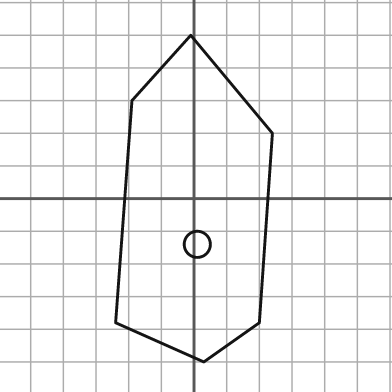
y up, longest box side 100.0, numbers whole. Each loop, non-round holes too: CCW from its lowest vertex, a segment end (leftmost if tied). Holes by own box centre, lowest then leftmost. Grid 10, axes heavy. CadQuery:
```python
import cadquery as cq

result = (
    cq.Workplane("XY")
    .moveTo(3.0, -50.0)
    .lineTo(20.0, -38.0)
    .lineTo(24.0, 20.0)
    .lineTo(-1.0, 50.0)
    .lineTo(-19.0, 30.0)
    .lineTo(-24.0, -38.0)
    .close()
    .moveTo(1.0, -14.0)
    .circle(4.0)
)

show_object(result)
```